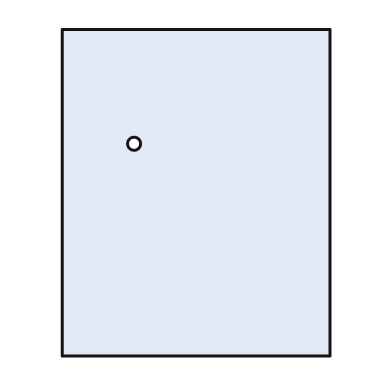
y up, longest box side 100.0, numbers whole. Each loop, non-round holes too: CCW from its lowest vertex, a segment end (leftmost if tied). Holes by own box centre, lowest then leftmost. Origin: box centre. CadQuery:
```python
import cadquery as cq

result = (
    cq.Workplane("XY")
    .moveTo(-41.0, -50.0)
    .lineTo(41.0, -50.0)
    .lineTo(41.0, 50.0)
    .lineTo(-41.0, 50.0)
    .close()
    .moveTo(-19.0, 15.0)
    .circle(2.0)
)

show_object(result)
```